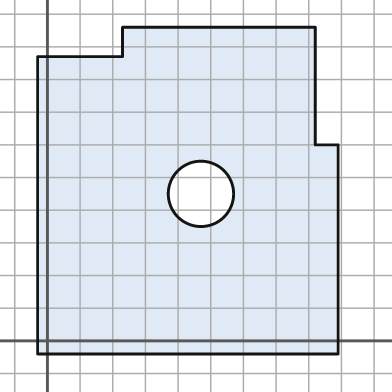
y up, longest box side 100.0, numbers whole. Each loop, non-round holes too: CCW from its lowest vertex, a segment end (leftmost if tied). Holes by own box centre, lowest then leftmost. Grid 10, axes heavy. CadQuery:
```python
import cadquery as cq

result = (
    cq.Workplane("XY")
    .moveTo(-3.0, -4.0)
    .lineTo(89.0, -4.0)
    .lineTo(89.0, 60.0)
    .lineTo(82.0, 60.0)
    .lineTo(82.0, 96.0)
    .lineTo(23.0, 96.0)
    .lineTo(23.0, 87.0)
    .lineTo(-3.0, 87.0)
    .close()
    .moveTo(47.0, 45.0)
    .circle(10.0)
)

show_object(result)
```